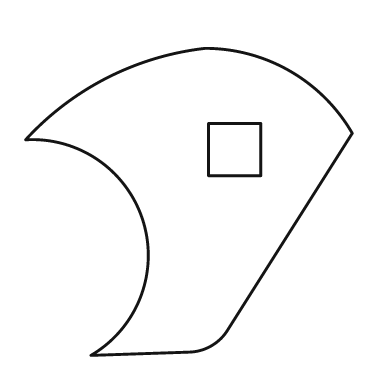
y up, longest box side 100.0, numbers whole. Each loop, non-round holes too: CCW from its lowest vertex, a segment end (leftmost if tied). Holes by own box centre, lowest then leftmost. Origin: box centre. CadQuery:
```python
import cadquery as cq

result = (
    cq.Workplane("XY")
    .moveTo(-30.0, -47.0)
    .lineTo(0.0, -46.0)
    .threePointArc((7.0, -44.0), (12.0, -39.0))
    .lineTo(50.0, 21.0)
    .threePointArc((31.0, 40.0), (5.0, 47.0))
    .threePointArc((-25.0, 38.0), (-50.0, 19.0))
    .threePointArc((-14.0, -6.0), (-30.0, -47.0))
    .close()
    .moveTo(6.0, 8.0)
    .lineTo(22.0, 8.0)
    .lineTo(22.0, 24.0)
    .lineTo(6.0, 24.0)
    .close()
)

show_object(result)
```